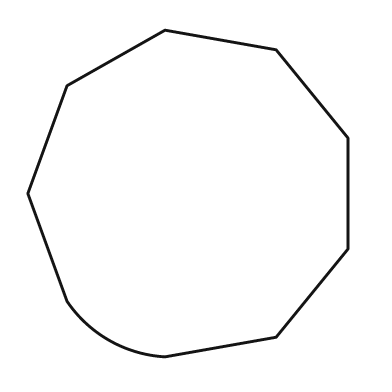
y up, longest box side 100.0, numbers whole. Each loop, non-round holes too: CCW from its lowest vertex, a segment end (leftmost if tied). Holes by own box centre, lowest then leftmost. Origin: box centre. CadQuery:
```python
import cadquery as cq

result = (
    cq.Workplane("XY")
    .moveTo(-7.0, -50.0)
    .lineTo(27.0, -44.0)
    .lineTo(49.0, -17.0)
    .lineTo(49.0, 17.0)
    .lineTo(27.0, 44.0)
    .lineTo(-7.0, 50.0)
    .lineTo(-37.0, 33.0)
    .lineTo(-49.0, 0.0)
    .lineTo(-37.0, -33.0)
    .threePointArc((-24.0, -45.0), (-7.0, -50.0))
    .close()
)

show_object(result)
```